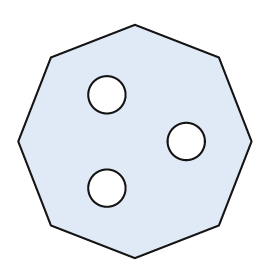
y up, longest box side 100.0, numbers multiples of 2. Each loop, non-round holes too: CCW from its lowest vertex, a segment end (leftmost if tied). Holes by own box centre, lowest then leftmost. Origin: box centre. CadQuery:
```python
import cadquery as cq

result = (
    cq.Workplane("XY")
    .moveTo(0.0, -50.0)
    .lineTo(36.0, -36.0)
    .lineTo(50.0, 0.0)
    .lineTo(36.0, 36.0)
    .lineTo(0.0, 50.0)
    .lineTo(-36.0, 36.0)
    .lineTo(-50.0, 0.0)
    .lineTo(-36.0, -36.0)
    .close()
    .moveTo(-12.0, -20.0)
    .circle(8.0)
    .moveTo(22.0, 0.0)
    .circle(8.0)
    .moveTo(-12.0, 20.0)
    .circle(8.0)
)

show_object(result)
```